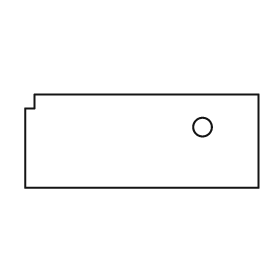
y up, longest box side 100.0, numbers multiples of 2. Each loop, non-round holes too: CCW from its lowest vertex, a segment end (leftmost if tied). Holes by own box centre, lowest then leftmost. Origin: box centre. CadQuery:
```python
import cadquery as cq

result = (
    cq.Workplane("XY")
    .moveTo(-50.0, -20.0)
    .lineTo(50.0, -20.0)
    .lineTo(50.0, 20.0)
    .lineTo(-46.0, 20.0)
    .lineTo(-46.0, 14.0)
    .lineTo(-50.0, 14.0)
    .close()
    .moveTo(26.0, 6.0)
    .circle(4.0)
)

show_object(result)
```